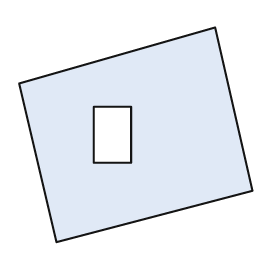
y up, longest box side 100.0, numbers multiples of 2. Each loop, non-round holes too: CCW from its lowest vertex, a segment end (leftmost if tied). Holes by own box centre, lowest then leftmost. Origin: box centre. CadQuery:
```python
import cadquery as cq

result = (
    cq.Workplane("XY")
    .moveTo(-34.0, -46.0)
    .lineTo(50.0, -24.0)
    .lineTo(34.0, 46.0)
    .lineTo(-50.0, 22.0)
    .close()
    .moveTo(-18.0, -12.0)
    .lineTo(-2.0, -12.0)
    .lineTo(-2.0, 12.0)
    .lineTo(-18.0, 12.0)
    .close()
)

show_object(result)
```